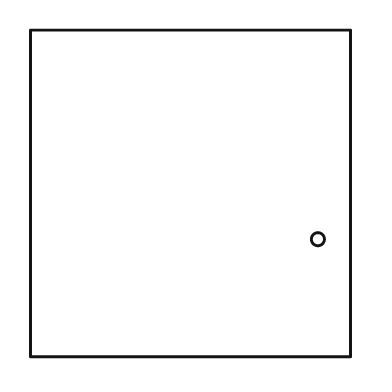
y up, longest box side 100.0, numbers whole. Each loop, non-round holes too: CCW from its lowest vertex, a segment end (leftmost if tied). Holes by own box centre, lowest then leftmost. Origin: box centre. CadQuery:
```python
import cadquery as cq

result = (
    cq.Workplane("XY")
    .moveTo(-49.0, -50.0)
    .lineTo(49.0, -50.0)
    .lineTo(49.0, 50.0)
    .lineTo(-49.0, 50.0)
    .close()
    .moveTo(39.0, -14.0)
    .circle(2.0)
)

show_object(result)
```